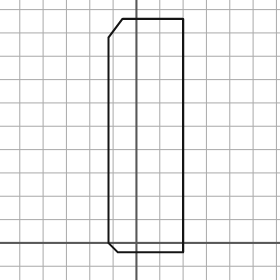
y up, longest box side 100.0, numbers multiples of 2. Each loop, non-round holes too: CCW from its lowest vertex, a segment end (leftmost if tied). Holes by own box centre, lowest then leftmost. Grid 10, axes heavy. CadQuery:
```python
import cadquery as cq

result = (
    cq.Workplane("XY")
    .moveTo(-8.0, -4.0)
    .lineTo(20.0, -4.0)
    .lineTo(20.0, 96.0)
    .lineTo(-6.0, 96.0)
    .lineTo(-12.0, 88.0)
    .lineTo(-12.0, 0.0)
    .close()
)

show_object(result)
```